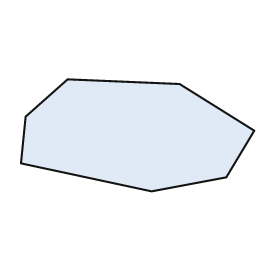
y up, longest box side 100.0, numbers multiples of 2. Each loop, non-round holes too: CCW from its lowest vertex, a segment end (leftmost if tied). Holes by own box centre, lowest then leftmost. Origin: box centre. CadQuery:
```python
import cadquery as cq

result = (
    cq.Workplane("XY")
    .moveTo(6.0, -24.0)
    .lineTo(38.0, -18.0)
    .lineTo(50.0, 2.0)
    .lineTo(18.0, 22.0)
    .lineTo(-30.0, 24.0)
    .lineTo(-48.0, 8.0)
    .lineTo(-50.0, -12.0)
    .close()
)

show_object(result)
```